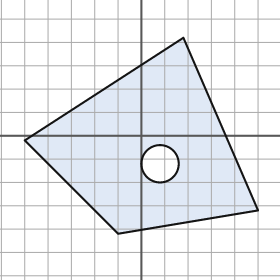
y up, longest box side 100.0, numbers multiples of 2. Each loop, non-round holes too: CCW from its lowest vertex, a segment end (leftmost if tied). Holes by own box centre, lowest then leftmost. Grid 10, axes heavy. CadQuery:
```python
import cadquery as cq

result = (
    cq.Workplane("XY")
    .moveTo(-10.0, -42.0)
    .lineTo(50.0, -32.0)
    .lineTo(18.0, 42.0)
    .lineTo(-50.0, -2.0)
    .close()
    .moveTo(8.0, -12.0)
    .circle(8.0)
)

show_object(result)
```